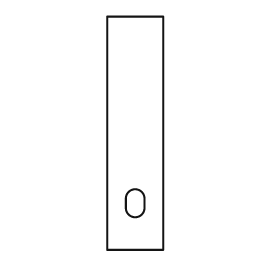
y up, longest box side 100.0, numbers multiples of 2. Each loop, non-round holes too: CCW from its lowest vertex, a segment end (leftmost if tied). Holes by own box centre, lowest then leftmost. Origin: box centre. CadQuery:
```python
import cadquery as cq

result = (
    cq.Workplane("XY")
    .moveTo(-12.0, -50.0)
    .lineTo(12.0, -50.0)
    .lineTo(12.0, 50.0)
    .lineTo(-12.0, 50.0)
    .close()
    .moveTo(-4.0, -32.0)
    .threePointArc((0.0, -36.0), (4.0, -32.0))
    .lineTo(4.0, -28.0)
    .threePointArc((0.0, -24.0), (-4.0, -28.0))
    .close()
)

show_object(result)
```